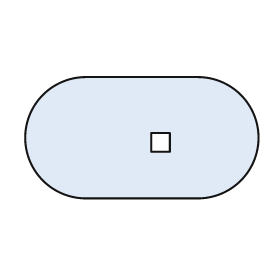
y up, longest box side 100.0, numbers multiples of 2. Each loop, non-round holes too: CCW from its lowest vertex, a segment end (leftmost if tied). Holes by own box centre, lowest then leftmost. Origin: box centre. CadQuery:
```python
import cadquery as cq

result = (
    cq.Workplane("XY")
    .moveTo(-24.0, -26.0)
    .lineTo(24.0, -26.0)
    .threePointArc((50.0, 0.0), (24.0, 26.0))
    .lineTo(-24.0, 26.0)
    .threePointArc((-50.0, 0.0), (-24.0, -26.0))
    .close()
    .moveTo(4.0, -6.0)
    .lineTo(12.0, -6.0)
    .lineTo(12.0, 2.0)
    .lineTo(4.0, 2.0)
    .close()
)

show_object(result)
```